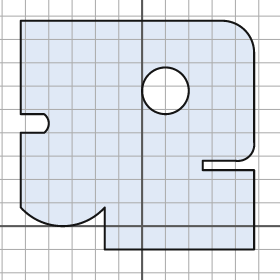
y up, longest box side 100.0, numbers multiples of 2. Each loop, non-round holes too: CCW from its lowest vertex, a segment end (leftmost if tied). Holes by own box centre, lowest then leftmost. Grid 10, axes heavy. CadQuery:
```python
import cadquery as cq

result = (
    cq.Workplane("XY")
    .moveTo(-16.0, -10.0)
    .lineTo(48.0, -10.0)
    .lineTo(48.0, 24.0)
    .lineTo(26.0, 24.0)
    .lineTo(26.0, 28.0)
    .lineTo(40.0, 28.0)
    .threePointArc((46.0, 30.0), (48.0, 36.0))
    .lineTo(48.0, 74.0)
    .threePointArc((44.0, 84.0), (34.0, 88.0))
    .lineTo(-52.0, 88.0)
    .lineTo(-52.0, 48.0)
    .lineTo(-42.0, 48.0)
    .threePointArc((-40.0, 44.0), (-42.0, 40.0))
    .lineTo(-52.0, 40.0)
    .lineTo(-52.0, 8.0)
    .threePointArc((-34.0, 0.0), (-16.0, 8.0))
    .close()
    .moveTo(10.0, 58.0)
    .circle(10.0)
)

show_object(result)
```